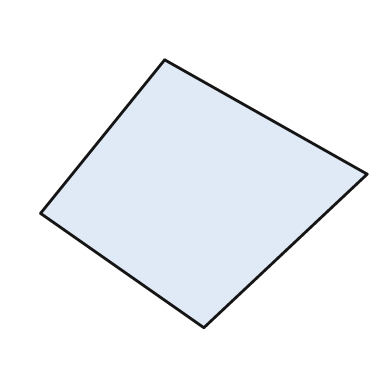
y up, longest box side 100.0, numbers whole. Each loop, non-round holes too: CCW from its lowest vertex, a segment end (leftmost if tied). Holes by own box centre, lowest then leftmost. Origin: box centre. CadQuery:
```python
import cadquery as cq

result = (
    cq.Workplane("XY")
    .moveTo(0.0, -41.0)
    .lineTo(50.0, 6.0)
    .lineTo(-12.0, 41.0)
    .lineTo(-50.0, -6.0)
    .close()
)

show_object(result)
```